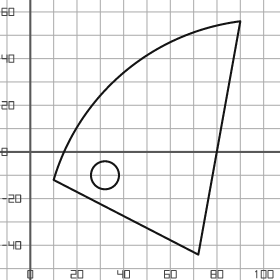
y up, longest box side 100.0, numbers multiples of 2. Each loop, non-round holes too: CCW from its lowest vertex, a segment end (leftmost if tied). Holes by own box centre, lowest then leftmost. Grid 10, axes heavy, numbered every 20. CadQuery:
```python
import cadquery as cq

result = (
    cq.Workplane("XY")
    .moveTo(72.0, -44.0)
    .lineTo(90.0, 56.0)
    .threePointArc((40.0, 34.0), (10.0, -12.0))
    .close()
    .moveTo(32.0, -10.0)
    .circle(6.0)
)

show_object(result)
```